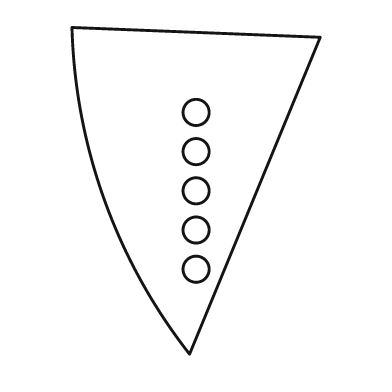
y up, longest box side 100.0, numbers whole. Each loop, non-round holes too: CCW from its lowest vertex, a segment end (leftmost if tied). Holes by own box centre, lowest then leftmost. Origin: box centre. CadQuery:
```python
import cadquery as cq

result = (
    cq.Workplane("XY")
    .moveTo(-2.0, -50.0)
    .lineTo(38.0, 47.0)
    .lineTo(-38.0, 50.0)
    .threePointArc((-28.0, -3.0), (-2.0, -50.0))
    .close()
    .moveTo(0.0, -24.0)
    .circle(4.0)
    .moveTo(0.0, -12.0)
    .circle(4.0)
    .moveTo(0.0, 0.0)
    .circle(4.0)
    .moveTo(0.0, 12.0)
    .circle(4.0)
    .moveTo(0.0, 24.0)
    .circle(4.0)
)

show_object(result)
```